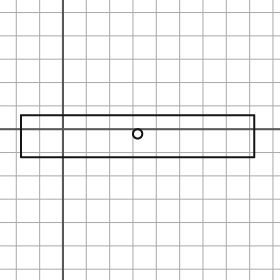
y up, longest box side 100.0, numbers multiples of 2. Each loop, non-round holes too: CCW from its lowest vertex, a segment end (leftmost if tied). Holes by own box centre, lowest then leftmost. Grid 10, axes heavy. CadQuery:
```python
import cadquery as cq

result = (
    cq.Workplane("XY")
    .moveTo(-18.0, -12.0)
    .lineTo(82.0, -12.0)
    .lineTo(82.0, 6.0)
    .lineTo(-18.0, 6.0)
    .close()
    .moveTo(32.0, -2.0)
    .circle(2.0)
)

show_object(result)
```